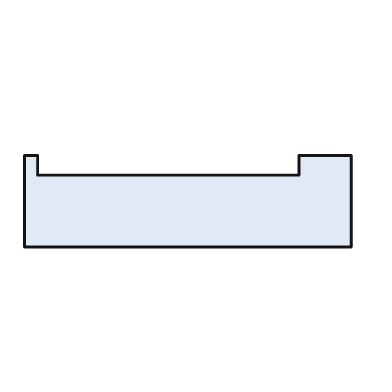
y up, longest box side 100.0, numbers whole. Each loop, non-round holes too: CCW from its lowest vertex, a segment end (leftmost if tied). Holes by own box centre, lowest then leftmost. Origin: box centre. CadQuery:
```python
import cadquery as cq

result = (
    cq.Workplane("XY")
    .moveTo(-50.0, -14.0)
    .lineTo(50.0, -14.0)
    .lineTo(50.0, 14.0)
    .lineTo(34.0, 14.0)
    .lineTo(34.0, 8.0)
    .lineTo(-46.0, 8.0)
    .lineTo(-46.0, 14.0)
    .lineTo(-50.0, 14.0)
    .close()
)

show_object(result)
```